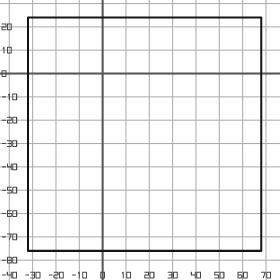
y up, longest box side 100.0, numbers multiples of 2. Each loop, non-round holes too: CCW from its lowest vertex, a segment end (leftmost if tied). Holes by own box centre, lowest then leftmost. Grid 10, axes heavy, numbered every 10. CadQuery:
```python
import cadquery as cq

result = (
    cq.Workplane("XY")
    .moveTo(-32.0, -76.0)
    .lineTo(68.0, -76.0)
    .lineTo(68.0, 24.0)
    .lineTo(-32.0, 24.0)
    .close()
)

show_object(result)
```